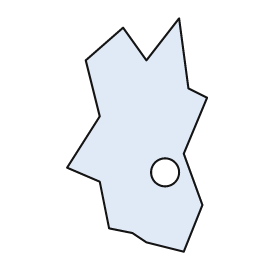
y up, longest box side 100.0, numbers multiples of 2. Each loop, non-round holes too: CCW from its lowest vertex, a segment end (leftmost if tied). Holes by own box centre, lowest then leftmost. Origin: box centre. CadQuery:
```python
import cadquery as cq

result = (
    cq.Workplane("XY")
    .moveTo(20.0, -50.0)
    .lineTo(28.0, -30.0)
    .lineTo(20.0, -8.0)
    .lineTo(30.0, 16.0)
    .lineTo(22.0, 20.0)
    .lineTo(18.0, 50.0)
    .lineTo(4.0, 32.0)
    .lineTo(-6.0, 46.0)
    .lineTo(-22.0, 32.0)
    .lineTo(-16.0, 8.0)
    .lineTo(-30.0, -14.0)
    .lineTo(-16.0, -20.0)
    .lineTo(-12.0, -40.0)
    .lineTo(-2.0, -42.0)
    .lineTo(4.0, -46.0)
    .close()
    .moveTo(12.0, -16.0)
    .circle(6.0)
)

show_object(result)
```